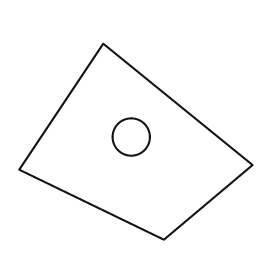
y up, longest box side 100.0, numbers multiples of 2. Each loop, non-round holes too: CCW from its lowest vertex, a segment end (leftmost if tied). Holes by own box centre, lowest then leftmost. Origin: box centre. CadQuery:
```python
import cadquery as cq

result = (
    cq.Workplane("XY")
    .moveTo(12.0, -42.0)
    .lineTo(50.0, -10.0)
    .lineTo(-14.0, 42.0)
    .lineTo(-50.0, -12.0)
    .close()
    .moveTo(-2.0, 2.0)
    .circle(8.0)
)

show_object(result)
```